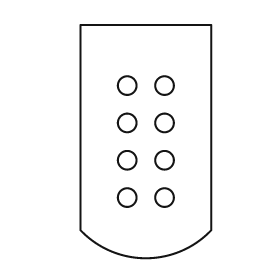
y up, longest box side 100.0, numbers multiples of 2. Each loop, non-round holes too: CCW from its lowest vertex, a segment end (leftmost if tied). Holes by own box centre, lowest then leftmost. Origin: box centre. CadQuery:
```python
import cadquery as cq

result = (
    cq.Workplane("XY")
    .moveTo(-28.0, -38.0)
    .threePointArc((0.0, -50.0), (28.0, -38.0))
    .lineTo(28.0, 50.0)
    .lineTo(-28.0, 50.0)
    .close()
    .moveTo(-8.0, -24.0)
    .circle(4.0)
    .moveTo(8.0, -24.0)
    .circle(4.0)
    .moveTo(-8.0, -8.0)
    .circle(4.0)
    .moveTo(8.0, -8.0)
    .circle(4.0)
    .moveTo(-8.0, 8.0)
    .circle(4.0)
    .moveTo(8.0, 8.0)
    .circle(4.0)
    .moveTo(-8.0, 24.0)
    .circle(4.0)
    .moveTo(8.0, 24.0)
    .circle(4.0)
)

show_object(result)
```